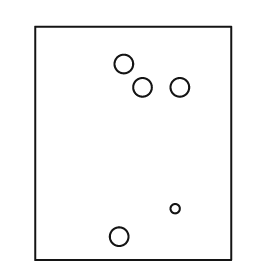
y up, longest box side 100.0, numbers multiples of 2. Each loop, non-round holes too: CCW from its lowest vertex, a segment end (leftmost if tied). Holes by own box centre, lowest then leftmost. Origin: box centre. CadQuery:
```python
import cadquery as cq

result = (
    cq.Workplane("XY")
    .moveTo(-42.0, -50.0)
    .lineTo(42.0, -50.0)
    .lineTo(42.0, 50.0)
    .lineTo(-42.0, 50.0)
    .close()
    .moveTo(-6.0, -40.0)
    .circle(4.0)
    .moveTo(18.0, -28.0)
    .circle(2.0)
    .moveTo(4.0, 24.0)
    .circle(4.0)
    .moveTo(20.0, 24.0)
    .circle(4.0)
    .moveTo(-4.0, 34.0)
    .circle(4.0)
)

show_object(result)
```